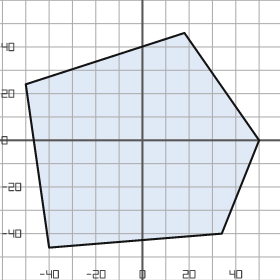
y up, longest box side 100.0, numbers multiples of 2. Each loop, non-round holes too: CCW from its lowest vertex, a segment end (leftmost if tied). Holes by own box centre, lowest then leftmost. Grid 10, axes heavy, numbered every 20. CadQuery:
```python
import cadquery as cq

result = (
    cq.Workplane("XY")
    .moveTo(-40.0, -46.0)
    .lineTo(34.0, -40.0)
    .lineTo(50.0, 0.0)
    .lineTo(18.0, 46.0)
    .lineTo(-50.0, 24.0)
    .close()
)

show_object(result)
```